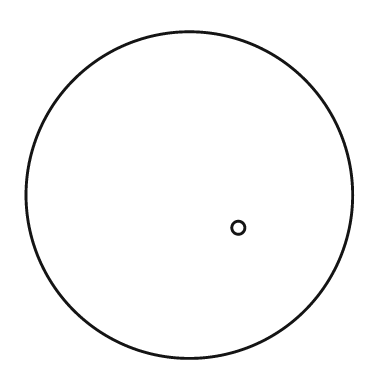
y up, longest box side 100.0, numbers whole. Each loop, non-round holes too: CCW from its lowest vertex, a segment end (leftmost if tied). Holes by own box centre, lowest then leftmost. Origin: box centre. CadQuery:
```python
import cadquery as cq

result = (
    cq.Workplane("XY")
    .moveTo(0.0, 0.0)
    .circle(50.0)
    .moveTo(15.0, -10.0)
    .circle(2.0)
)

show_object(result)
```